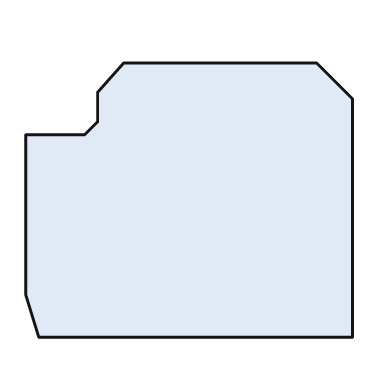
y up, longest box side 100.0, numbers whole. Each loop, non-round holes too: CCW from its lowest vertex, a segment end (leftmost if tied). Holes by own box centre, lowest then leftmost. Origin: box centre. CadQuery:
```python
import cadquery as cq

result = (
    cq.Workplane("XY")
    .moveTo(-46.0, -42.0)
    .lineTo(50.0, -42.0)
    .lineTo(50.0, 31.0)
    .lineTo(39.0, 42.0)
    .lineTo(-20.0, 42.0)
    .lineTo(-28.0, 33.0)
    .lineTo(-28.0, 24.0)
    .lineTo(-32.0, 20.0)
    .lineTo(-50.0, 20.0)
    .lineTo(-50.0, -29.0)
    .close()
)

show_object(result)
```